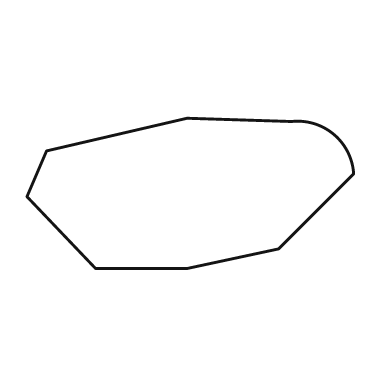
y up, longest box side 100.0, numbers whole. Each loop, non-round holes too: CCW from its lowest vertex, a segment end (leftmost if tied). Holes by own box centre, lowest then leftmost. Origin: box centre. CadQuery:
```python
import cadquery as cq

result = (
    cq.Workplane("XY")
    .moveTo(-29.0, -23.0)
    .lineTo(-1.0, -23.0)
    .lineTo(27.0, -17.0)
    .lineTo(50.0, 6.0)
    .threePointArc((44.0, 18.0), (31.0, 22.0))
    .lineTo(-1.0, 23.0)
    .lineTo(-44.0, 13.0)
    .lineTo(-50.0, -1.0)
    .close()
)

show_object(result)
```